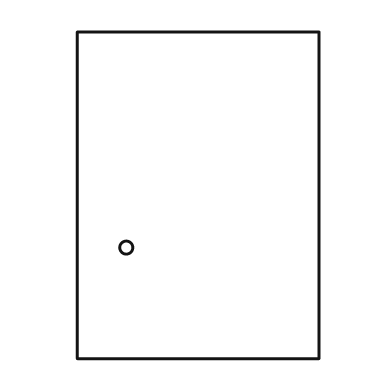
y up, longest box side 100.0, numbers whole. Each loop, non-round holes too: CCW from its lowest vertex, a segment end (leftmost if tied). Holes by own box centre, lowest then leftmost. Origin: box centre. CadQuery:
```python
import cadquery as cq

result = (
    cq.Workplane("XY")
    .moveTo(-37.0, -50.0)
    .lineTo(37.0, -50.0)
    .lineTo(37.0, 50.0)
    .lineTo(-37.0, 50.0)
    .close()
    .moveTo(-22.0, -16.0)
    .circle(2.0)
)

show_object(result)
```